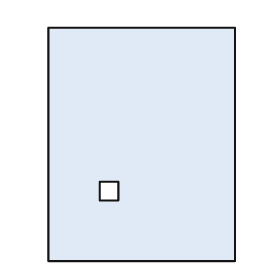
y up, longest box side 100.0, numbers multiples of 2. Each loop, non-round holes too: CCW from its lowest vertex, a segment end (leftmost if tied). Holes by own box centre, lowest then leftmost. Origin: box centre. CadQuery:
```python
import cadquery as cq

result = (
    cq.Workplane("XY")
    .moveTo(-40.0, -50.0)
    .lineTo(40.0, -50.0)
    .lineTo(40.0, 50.0)
    .lineTo(-40.0, 50.0)
    .close()
    .moveTo(-18.0, -24.0)
    .lineTo(-10.0, -24.0)
    .lineTo(-10.0, -16.0)
    .lineTo(-18.0, -16.0)
    .close()
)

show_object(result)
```